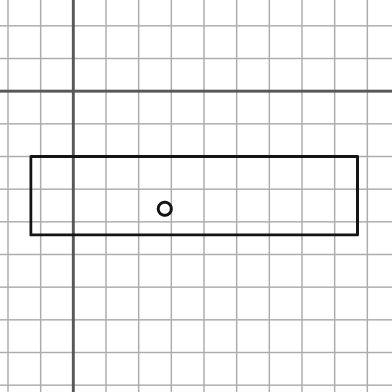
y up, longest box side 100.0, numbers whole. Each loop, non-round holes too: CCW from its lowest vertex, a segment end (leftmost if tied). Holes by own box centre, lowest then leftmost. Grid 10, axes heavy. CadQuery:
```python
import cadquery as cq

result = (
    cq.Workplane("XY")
    .moveTo(-13.0, -44.0)
    .lineTo(87.0, -44.0)
    .lineTo(87.0, -20.0)
    .lineTo(-13.0, -20.0)
    .close()
    .moveTo(28.0, -36.0)
    .circle(2.0)
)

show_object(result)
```